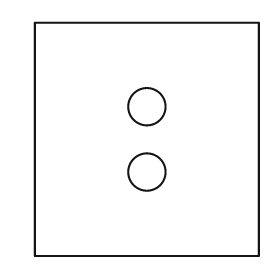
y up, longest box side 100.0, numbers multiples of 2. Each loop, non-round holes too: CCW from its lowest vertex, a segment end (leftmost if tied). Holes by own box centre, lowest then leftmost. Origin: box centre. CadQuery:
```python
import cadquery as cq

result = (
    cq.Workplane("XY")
    .moveTo(-48.0, -50.0)
    .lineTo(48.0, -50.0)
    .lineTo(48.0, 50.0)
    .lineTo(-48.0, 50.0)
    .close()
    .moveTo(0.0, -14.0)
    .circle(8.0)
    .moveTo(0.0, 14.0)
    .circle(8.0)
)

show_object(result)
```